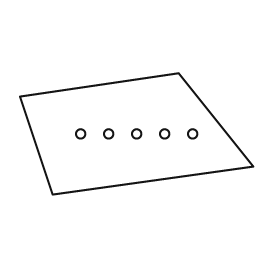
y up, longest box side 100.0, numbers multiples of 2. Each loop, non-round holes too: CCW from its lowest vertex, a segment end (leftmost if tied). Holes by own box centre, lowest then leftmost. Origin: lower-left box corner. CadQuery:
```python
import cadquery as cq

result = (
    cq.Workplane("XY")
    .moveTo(14.0, 0.0)
    .lineTo(100.0, 12.0)
    .lineTo(68.0, 52.0)
    .lineTo(0.0, 42.0)
    .close()
    .moveTo(26.0, 26.0)
    .circle(2.0)
    .moveTo(38.0, 26.0)
    .circle(2.0)
    .moveTo(50.0, 26.0)
    .circle(2.0)
    .moveTo(62.0, 26.0)
    .circle(2.0)
    .moveTo(74.0, 26.0)
    .circle(2.0)
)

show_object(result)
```